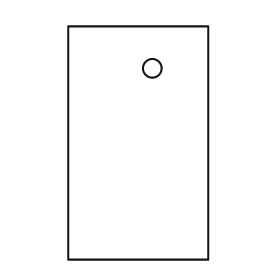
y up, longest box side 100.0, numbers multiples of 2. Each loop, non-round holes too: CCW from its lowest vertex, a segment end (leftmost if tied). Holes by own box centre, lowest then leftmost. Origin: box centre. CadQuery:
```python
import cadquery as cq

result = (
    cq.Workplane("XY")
    .moveTo(-30.0, -50.0)
    .lineTo(30.0, -50.0)
    .lineTo(30.0, 50.0)
    .lineTo(-30.0, 50.0)
    .close()
    .moveTo(6.0, 32.0)
    .circle(4.0)
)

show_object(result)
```